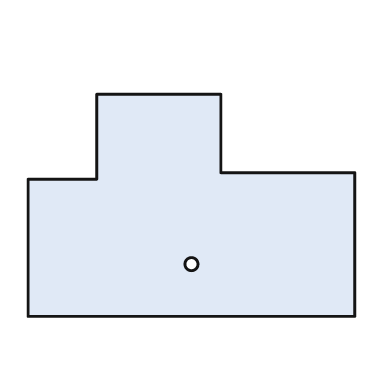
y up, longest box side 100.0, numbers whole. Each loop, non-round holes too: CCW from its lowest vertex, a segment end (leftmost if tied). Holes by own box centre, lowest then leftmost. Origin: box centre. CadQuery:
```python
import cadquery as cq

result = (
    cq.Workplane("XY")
    .moveTo(-50.0, -34.0)
    .lineTo(50.0, -34.0)
    .lineTo(50.0, 10.0)
    .lineTo(9.0, 10.0)
    .lineTo(9.0, 34.0)
    .lineTo(-29.0, 34.0)
    .lineTo(-29.0, 8.0)
    .lineTo(-50.0, 8.0)
    .close()
    .moveTo(0.0, -18.0)
    .circle(2.0)
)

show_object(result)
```